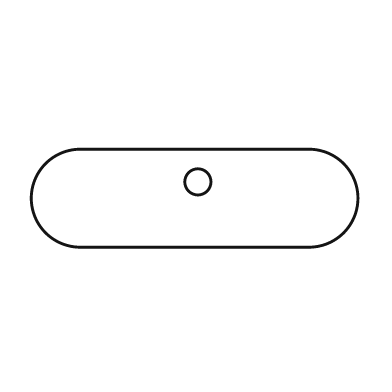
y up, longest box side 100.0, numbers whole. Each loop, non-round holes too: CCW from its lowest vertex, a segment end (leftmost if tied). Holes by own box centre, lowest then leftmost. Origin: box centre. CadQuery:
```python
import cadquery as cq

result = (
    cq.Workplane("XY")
    .moveTo(-35.0, -15.0)
    .lineTo(35.0, -15.0)
    .threePointArc((50.0, 0.0), (35.0, 15.0))
    .lineTo(-35.0, 15.0)
    .threePointArc((-50.0, 0.0), (-35.0, -15.0))
    .close()
    .moveTo(1.0, 5.0)
    .circle(4.0)
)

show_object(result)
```